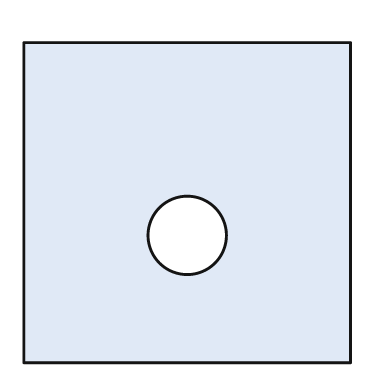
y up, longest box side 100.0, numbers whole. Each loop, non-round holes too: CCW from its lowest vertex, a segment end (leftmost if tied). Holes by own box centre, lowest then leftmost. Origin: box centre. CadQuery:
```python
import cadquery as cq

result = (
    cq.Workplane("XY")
    .moveTo(-50.0, -49.0)
    .lineTo(50.0, -49.0)
    .lineTo(50.0, 49.0)
    .lineTo(-50.0, 49.0)
    .close()
    .moveTo(0.0, -10.0)
    .circle(12.0)
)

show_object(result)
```